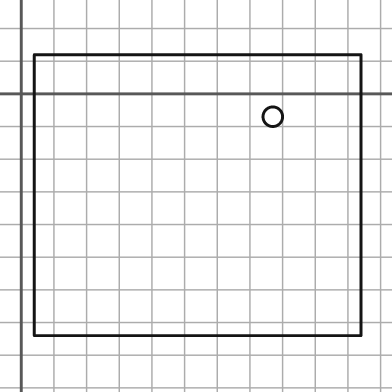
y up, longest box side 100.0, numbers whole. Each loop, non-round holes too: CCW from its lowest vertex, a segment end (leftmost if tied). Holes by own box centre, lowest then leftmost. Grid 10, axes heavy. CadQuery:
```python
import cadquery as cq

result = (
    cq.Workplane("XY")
    .moveTo(4.0, -74.0)
    .lineTo(104.0, -74.0)
    .lineTo(104.0, 12.0)
    .lineTo(4.0, 12.0)
    .close()
    .moveTo(77.0, -7.0)
    .circle(3.0)
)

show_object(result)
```